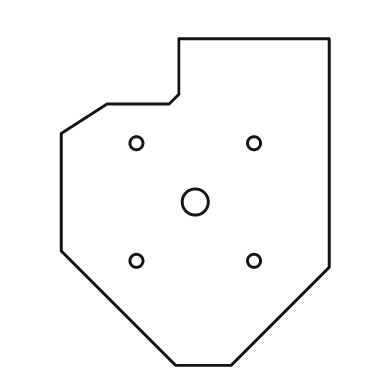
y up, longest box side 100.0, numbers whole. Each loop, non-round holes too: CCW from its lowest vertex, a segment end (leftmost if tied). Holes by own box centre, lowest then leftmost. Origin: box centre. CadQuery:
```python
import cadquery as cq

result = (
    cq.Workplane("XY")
    .moveTo(-6.0, -50.0)
    .lineTo(11.0, -50.0)
    .lineTo(41.0, -20.0)
    .lineTo(41.0, 50.0)
    .lineTo(-5.0, 50.0)
    .lineTo(-5.0, 33.0)
    .lineTo(-8.0, 30.0)
    .lineTo(-27.0, 30.0)
    .lineTo(-41.0, 21.0)
    .lineTo(-41.0, -15.0)
    .close()
    .moveTo(-18.0, -18.0)
    .circle(2.0)
    .moveTo(18.0, -18.0)
    .circle(2.0)
    .moveTo(0.0, 0.0)
    .circle(4.0)
    .moveTo(-18.0, 18.0)
    .circle(2.0)
    .moveTo(18.0, 18.0)
    .circle(2.0)
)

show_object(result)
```